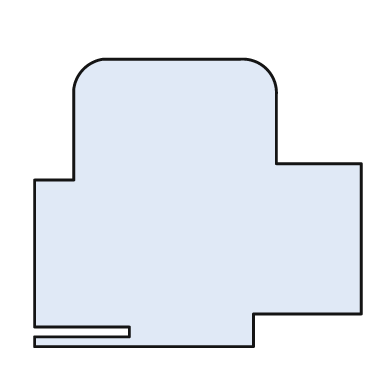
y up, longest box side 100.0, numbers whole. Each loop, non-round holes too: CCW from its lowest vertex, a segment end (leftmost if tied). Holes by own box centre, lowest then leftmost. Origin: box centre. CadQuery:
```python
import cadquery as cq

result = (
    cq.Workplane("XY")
    .moveTo(-50.0, -44.0)
    .lineTo(17.0, -44.0)
    .lineTo(17.0, -34.0)
    .lineTo(50.0, -34.0)
    .lineTo(50.0, 12.0)
    .lineTo(24.0, 12.0)
    .lineTo(24.0, 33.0)
    .threePointArc((21.0, 41.0), (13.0, 44.0))
    .lineTo(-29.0, 44.0)
    .threePointArc((-35.0, 41.0), (-38.0, 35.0))
    .lineTo(-38.0, 7.0)
    .lineTo(-50.0, 7.0)
    .lineTo(-50.0, -38.0)
    .lineTo(-21.0, -38.0)
    .lineTo(-21.0, -41.0)
    .lineTo(-50.0, -41.0)
    .close()
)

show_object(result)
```